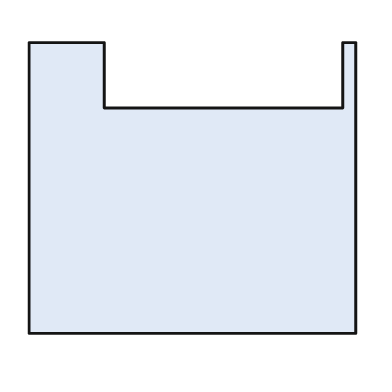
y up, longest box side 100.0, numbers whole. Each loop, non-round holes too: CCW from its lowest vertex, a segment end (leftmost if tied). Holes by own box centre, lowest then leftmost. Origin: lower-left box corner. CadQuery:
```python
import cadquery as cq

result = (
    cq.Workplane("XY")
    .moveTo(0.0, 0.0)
    .lineTo(100.0, 0.0)
    .lineTo(100.0, 89.0)
    .lineTo(96.0, 89.0)
    .lineTo(96.0, 69.0)
    .lineTo(23.0, 69.0)
    .lineTo(23.0, 89.0)
    .lineTo(0.0, 89.0)
    .close()
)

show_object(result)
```